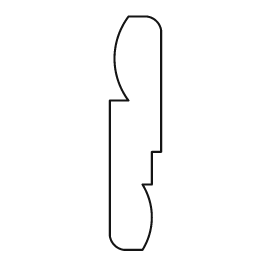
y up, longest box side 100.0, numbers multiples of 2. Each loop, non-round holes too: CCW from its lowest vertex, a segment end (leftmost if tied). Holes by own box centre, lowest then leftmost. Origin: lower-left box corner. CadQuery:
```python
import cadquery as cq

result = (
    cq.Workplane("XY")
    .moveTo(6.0, 0.0)
    .lineTo(14.0, 0.0)
    .threePointArc((18.0, 14.0), (14.0, 28.0))
    .lineTo(18.0, 28.0)
    .lineTo(18.0, 42.0)
    .lineTo(22.0, 42.0)
    .lineTo(22.0, 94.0)
    .threePointArc((20.0, 98.0), (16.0, 100.0))
    .lineTo(8.0, 100.0)
    .threePointArc((2.0, 82.0), (8.0, 64.0))
    .lineTo(0.0, 64.0)
    .lineTo(0.0, 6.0)
    .threePointArc((2.0, 2.0), (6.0, 0.0))
    .close()
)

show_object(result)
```